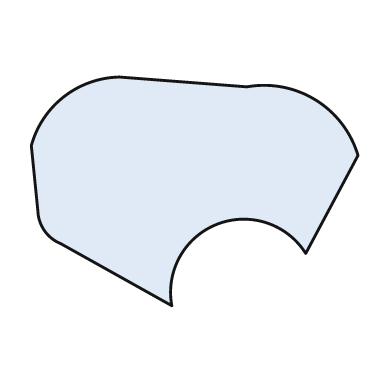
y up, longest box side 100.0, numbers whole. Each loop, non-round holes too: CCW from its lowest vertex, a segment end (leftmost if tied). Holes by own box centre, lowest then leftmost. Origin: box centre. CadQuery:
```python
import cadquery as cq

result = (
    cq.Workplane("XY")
    .moveTo(-7.0, -35.0)
    .threePointArc((7.0, -10.0), (34.0, -19.0))
    .lineTo(50.0, 11.0)
    .threePointArc((37.0, 28.0), (16.0, 32.0))
    .lineTo(-23.0, 35.0)
    .threePointArc((-40.0, 29.0), (-50.0, 14.0))
    .lineTo(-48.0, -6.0)
    .threePointArc((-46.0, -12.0), (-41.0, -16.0))
    .close()
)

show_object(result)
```